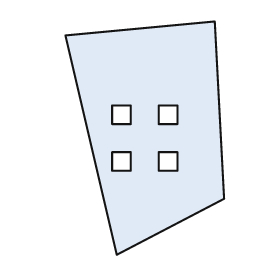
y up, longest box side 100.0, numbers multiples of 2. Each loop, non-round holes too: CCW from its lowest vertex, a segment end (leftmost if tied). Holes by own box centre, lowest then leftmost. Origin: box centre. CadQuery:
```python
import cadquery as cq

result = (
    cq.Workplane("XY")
    .moveTo(-12.0, -50.0)
    .lineTo(34.0, -26.0)
    .lineTo(30.0, 50.0)
    .lineTo(-34.0, 44.0)
    .close()
    .moveTo(-14.0, -14.0)
    .lineTo(-6.0, -14.0)
    .lineTo(-6.0, -6.0)
    .lineTo(-14.0, -6.0)
    .close()
    .moveTo(6.0, -14.0)
    .lineTo(14.0, -14.0)
    .lineTo(14.0, -6.0)
    .lineTo(6.0, -6.0)
    .close()
    .moveTo(-14.0, 6.0)
    .lineTo(-6.0, 6.0)
    .lineTo(-6.0, 14.0)
    .lineTo(-14.0, 14.0)
    .close()
    .moveTo(6.0, 6.0)
    .lineTo(14.0, 6.0)
    .lineTo(14.0, 14.0)
    .lineTo(6.0, 14.0)
    .close()
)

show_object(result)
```